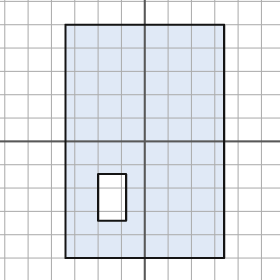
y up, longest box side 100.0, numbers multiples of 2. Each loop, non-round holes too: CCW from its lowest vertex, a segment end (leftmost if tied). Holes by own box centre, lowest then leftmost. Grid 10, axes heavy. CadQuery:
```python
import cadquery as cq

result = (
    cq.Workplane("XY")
    .moveTo(-34.0, -50.0)
    .lineTo(34.0, -50.0)
    .lineTo(34.0, 50.0)
    .lineTo(-34.0, 50.0)
    .close()
    .moveTo(-20.0, -34.0)
    .lineTo(-8.0, -34.0)
    .lineTo(-8.0, -14.0)
    .lineTo(-20.0, -14.0)
    .close()
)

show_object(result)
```